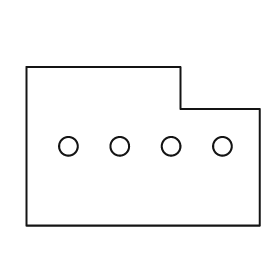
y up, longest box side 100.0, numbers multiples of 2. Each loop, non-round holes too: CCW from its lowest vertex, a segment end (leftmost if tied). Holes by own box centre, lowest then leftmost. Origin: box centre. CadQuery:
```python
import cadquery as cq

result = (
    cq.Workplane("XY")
    .moveTo(-50.0, -34.0)
    .lineTo(50.0, -34.0)
    .lineTo(50.0, 16.0)
    .lineTo(16.0, 16.0)
    .lineTo(16.0, 34.0)
    .lineTo(-50.0, 34.0)
    .close()
    .moveTo(-32.0, 0.0)
    .circle(4.0)
    .moveTo(-10.0, 0.0)
    .circle(4.0)
    .moveTo(12.0, 0.0)
    .circle(4.0)
    .moveTo(34.0, 0.0)
    .circle(4.0)
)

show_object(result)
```